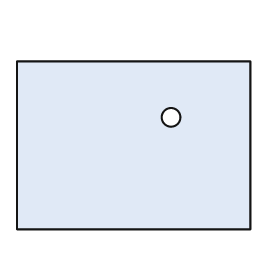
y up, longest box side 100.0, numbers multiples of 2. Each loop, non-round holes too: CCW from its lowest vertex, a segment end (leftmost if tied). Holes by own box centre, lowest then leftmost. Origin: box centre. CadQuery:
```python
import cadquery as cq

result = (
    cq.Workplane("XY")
    .moveTo(-50.0, -36.0)
    .lineTo(50.0, -36.0)
    .lineTo(50.0, 36.0)
    .lineTo(-50.0, 36.0)
    .close()
    .moveTo(16.0, 12.0)
    .circle(4.0)
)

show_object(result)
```